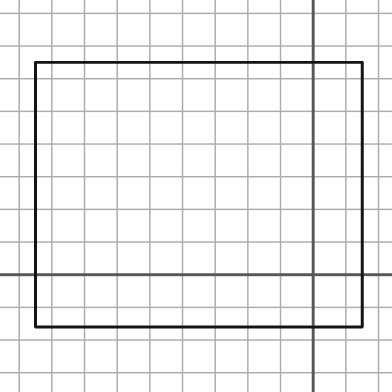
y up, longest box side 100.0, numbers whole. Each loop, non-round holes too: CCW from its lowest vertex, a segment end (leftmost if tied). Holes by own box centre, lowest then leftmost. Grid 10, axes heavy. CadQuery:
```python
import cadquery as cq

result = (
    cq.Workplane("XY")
    .moveTo(-85.0, -16.0)
    .lineTo(15.0, -16.0)
    .lineTo(15.0, 65.0)
    .lineTo(-85.0, 65.0)
    .close()
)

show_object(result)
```